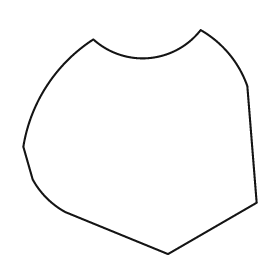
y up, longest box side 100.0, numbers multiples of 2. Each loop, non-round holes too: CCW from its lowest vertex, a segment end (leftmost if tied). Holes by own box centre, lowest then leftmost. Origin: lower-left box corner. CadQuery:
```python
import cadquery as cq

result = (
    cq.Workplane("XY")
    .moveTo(62.0, 0.0)
    .lineTo(100.0, 22.0)
    .lineTo(96.0, 72.0)
    .threePointArc((88.0, 86.0), (76.0, 96.0))
    .threePointArc((54.0, 84.0), (30.0, 92.0))
    .threePointArc((10.0, 72.0), (0.0, 46.0))
    .lineTo(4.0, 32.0)
    .threePointArc((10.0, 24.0), (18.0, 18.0))
    .close()
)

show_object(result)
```